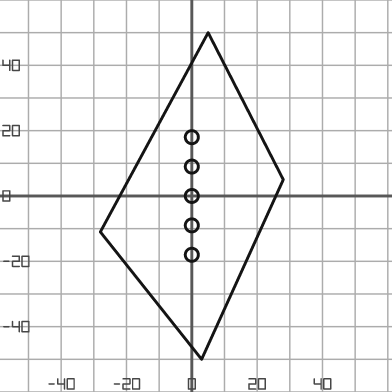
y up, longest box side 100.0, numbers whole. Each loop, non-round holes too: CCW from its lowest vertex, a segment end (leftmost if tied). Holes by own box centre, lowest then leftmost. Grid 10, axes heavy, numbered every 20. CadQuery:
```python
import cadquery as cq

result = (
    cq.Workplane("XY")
    .moveTo(3.0, -50.0)
    .lineTo(28.0, 5.0)
    .lineTo(5.0, 50.0)
    .lineTo(-28.0, -11.0)
    .close()
    .moveTo(0.0, -18.0)
    .circle(2.0)
    .moveTo(0.0, -9.0)
    .circle(2.0)
    .moveTo(0.0, 0.0)
    .circle(2.0)
    .moveTo(0.0, 9.0)
    .circle(2.0)
    .moveTo(0.0, 18.0)
    .circle(2.0)
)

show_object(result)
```